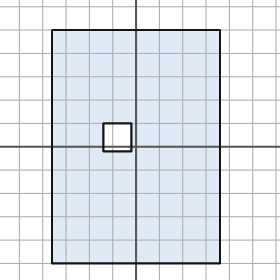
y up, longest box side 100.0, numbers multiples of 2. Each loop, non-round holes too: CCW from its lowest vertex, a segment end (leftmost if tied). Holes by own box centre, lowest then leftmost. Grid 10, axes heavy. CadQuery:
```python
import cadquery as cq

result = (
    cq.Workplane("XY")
    .moveTo(-36.0, -50.0)
    .lineTo(36.0, -50.0)
    .lineTo(36.0, 50.0)
    .lineTo(-36.0, 50.0)
    .close()
    .moveTo(-14.0, -2.0)
    .lineTo(-2.0, -2.0)
    .lineTo(-2.0, 10.0)
    .lineTo(-14.0, 10.0)
    .close()
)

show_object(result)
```